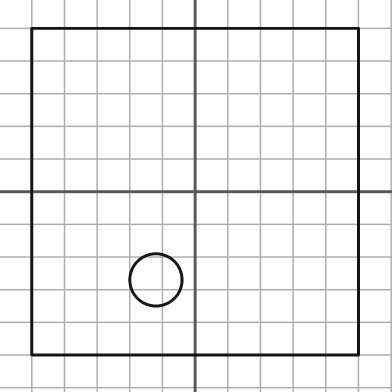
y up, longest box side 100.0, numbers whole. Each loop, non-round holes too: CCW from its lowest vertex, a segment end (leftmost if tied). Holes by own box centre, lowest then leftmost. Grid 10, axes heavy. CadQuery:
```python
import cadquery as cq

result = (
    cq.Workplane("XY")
    .moveTo(-50.0, -50.0)
    .lineTo(50.0, -50.0)
    .lineTo(50.0, 50.0)
    .lineTo(-50.0, 50.0)
    .close()
    .moveTo(-12.0, -27.0)
    .circle(8.0)
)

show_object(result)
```